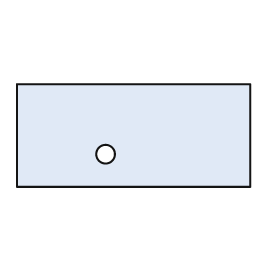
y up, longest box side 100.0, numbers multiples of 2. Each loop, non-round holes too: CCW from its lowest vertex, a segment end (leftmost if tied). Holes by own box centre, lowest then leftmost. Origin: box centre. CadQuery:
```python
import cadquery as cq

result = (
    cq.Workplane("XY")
    .moveTo(-50.0, -22.0)
    .lineTo(50.0, -22.0)
    .lineTo(50.0, 22.0)
    .lineTo(-50.0, 22.0)
    .close()
    .moveTo(-12.0, -8.0)
    .circle(4.0)
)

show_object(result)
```